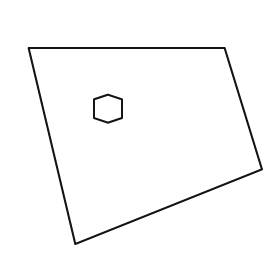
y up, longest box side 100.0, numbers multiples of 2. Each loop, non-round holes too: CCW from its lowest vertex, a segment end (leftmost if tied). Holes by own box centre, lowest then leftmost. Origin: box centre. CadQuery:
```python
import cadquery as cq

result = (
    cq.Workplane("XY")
    .moveTo(-30.0, -42.0)
    .lineTo(50.0, -10.0)
    .lineTo(34.0, 42.0)
    .lineTo(-50.0, 42.0)
    .close()
    .moveTo(-16.0, 10.0)
    .lineTo(-10.0, 12.0)
    .lineTo(-10.0, 20.0)
    .lineTo(-16.0, 22.0)
    .lineTo(-22.0, 20.0)
    .lineTo(-22.0, 12.0)
    .close()
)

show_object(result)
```